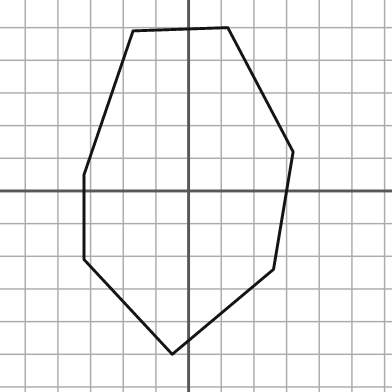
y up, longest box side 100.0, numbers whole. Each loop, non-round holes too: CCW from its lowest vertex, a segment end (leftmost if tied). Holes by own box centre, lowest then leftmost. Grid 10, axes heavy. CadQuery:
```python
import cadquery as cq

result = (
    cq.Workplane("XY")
    .moveTo(-5.0, -50.0)
    .lineTo(26.0, -24.0)
    .lineTo(32.0, 12.0)
    .lineTo(12.0, 50.0)
    .lineTo(-17.0, 49.0)
    .lineTo(-32.0, 5.0)
    .lineTo(-32.0, -21.0)
    .close()
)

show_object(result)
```